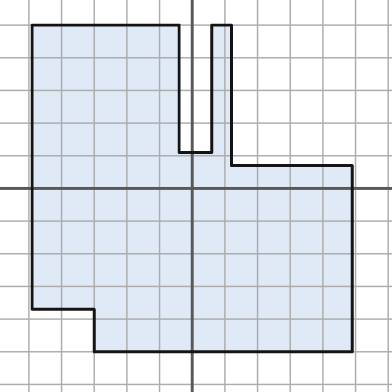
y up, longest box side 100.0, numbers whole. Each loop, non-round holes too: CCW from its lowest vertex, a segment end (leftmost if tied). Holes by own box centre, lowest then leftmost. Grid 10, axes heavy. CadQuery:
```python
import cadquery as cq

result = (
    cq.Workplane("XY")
    .moveTo(-30.0, -50.0)
    .lineTo(49.0, -50.0)
    .lineTo(49.0, 7.0)
    .lineTo(12.0, 7.0)
    .lineTo(12.0, 50.0)
    .lineTo(6.0, 50.0)
    .lineTo(6.0, 11.0)
    .lineTo(-4.0, 11.0)
    .lineTo(-4.0, 50.0)
    .lineTo(-49.0, 50.0)
    .lineTo(-49.0, -37.0)
    .lineTo(-30.0, -37.0)
    .close()
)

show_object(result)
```